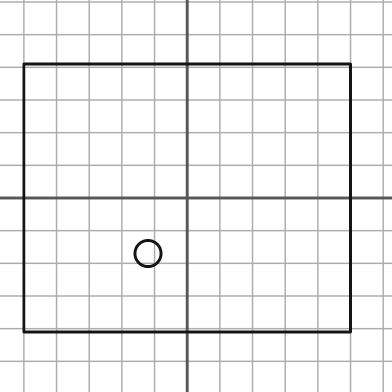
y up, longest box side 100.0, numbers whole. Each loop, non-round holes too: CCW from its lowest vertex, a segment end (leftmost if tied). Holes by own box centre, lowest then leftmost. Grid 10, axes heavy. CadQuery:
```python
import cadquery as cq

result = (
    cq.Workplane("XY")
    .moveTo(-50.0, -41.0)
    .lineTo(50.0, -41.0)
    .lineTo(50.0, 41.0)
    .lineTo(-50.0, 41.0)
    .close()
    .moveTo(-12.0, -17.0)
    .circle(4.0)
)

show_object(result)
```